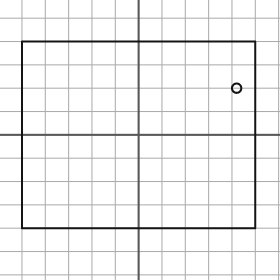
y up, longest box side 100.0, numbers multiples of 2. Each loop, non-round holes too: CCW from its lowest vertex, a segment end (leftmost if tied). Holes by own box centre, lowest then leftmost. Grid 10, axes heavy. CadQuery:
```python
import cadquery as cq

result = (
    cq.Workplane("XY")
    .moveTo(-50.0, -40.0)
    .lineTo(50.0, -40.0)
    .lineTo(50.0, 40.0)
    .lineTo(-50.0, 40.0)
    .close()
    .moveTo(42.0, 20.0)
    .circle(2.0)
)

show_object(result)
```